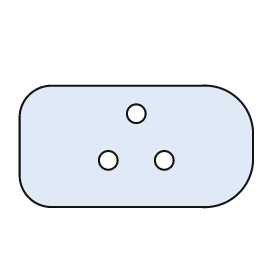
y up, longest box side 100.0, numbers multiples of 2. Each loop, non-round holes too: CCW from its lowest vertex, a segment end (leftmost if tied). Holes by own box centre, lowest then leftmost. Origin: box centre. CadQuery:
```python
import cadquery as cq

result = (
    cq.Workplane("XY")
    .moveTo(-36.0, -26.0)
    .lineTo(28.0, -26.0)
    .threePointArc((44.0, -20.0), (50.0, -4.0))
    .lineTo(50.0, 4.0)
    .threePointArc((44.0, 20.0), (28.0, 26.0))
    .lineTo(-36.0, 26.0)
    .threePointArc((-46.0, 22.0), (-50.0, 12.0))
    .lineTo(-50.0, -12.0)
    .threePointArc((-46.0, -22.0), (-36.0, -26.0))
    .close()
    .moveTo(-12.0, -6.0)
    .circle(4.0)
    .moveTo(12.0, -6.0)
    .circle(4.0)
    .moveTo(0.0, 14.0)
    .circle(4.0)
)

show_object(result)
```